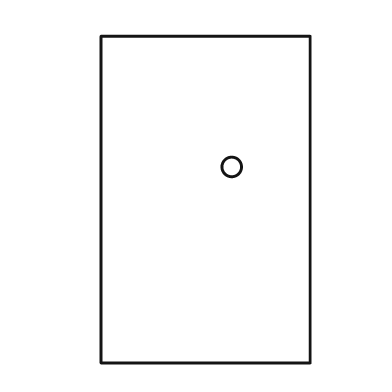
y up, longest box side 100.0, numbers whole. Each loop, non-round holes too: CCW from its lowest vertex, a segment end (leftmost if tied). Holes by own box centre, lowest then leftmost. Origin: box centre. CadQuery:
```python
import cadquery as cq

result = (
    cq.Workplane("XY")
    .moveTo(-32.0, -50.0)
    .lineTo(32.0, -50.0)
    .lineTo(32.0, 50.0)
    .lineTo(-32.0, 50.0)
    .close()
    .moveTo(8.0, 10.0)
    .circle(3.0)
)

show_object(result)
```